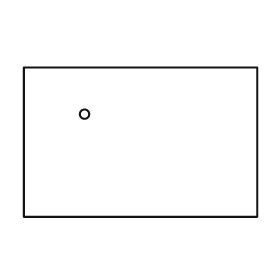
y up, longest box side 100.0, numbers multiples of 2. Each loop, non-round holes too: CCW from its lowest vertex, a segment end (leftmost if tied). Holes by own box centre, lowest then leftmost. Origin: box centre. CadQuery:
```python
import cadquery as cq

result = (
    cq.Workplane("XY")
    .moveTo(-50.0, -32.0)
    .lineTo(50.0, -32.0)
    .lineTo(50.0, 32.0)
    .lineTo(-50.0, 32.0)
    .close()
    .moveTo(-24.0, 12.0)
    .circle(2.0)
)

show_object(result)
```